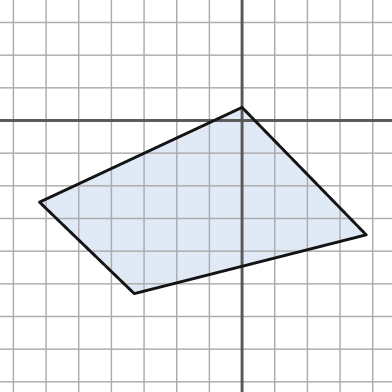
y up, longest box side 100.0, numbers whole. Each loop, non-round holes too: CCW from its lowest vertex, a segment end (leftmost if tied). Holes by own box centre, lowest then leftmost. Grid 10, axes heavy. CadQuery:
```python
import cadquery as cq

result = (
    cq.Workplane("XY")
    .moveTo(-33.0, -53.0)
    .lineTo(38.0, -35.0)
    .lineTo(0.0, 4.0)
    .lineTo(-62.0, -25.0)
    .close()
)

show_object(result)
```